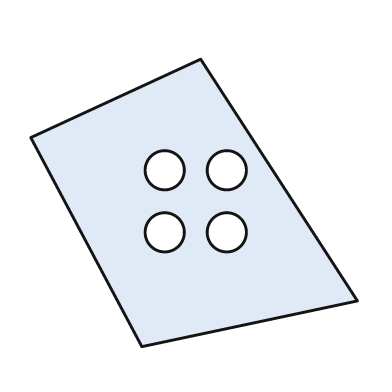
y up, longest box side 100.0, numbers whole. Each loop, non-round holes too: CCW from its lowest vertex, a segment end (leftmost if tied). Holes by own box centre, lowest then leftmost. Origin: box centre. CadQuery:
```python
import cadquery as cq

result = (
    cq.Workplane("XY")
    .moveTo(-16.0, -44.0)
    .lineTo(50.0, -30.0)
    .lineTo(2.0, 44.0)
    .lineTo(-50.0, 20.0)
    .close()
    .moveTo(-9.0, -9.0)
    .circle(6.0)
    .moveTo(10.0, -9.0)
    .circle(6.0)
    .moveTo(-9.0, 10.0)
    .circle(6.0)
    .moveTo(10.0, 10.0)
    .circle(6.0)
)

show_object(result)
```